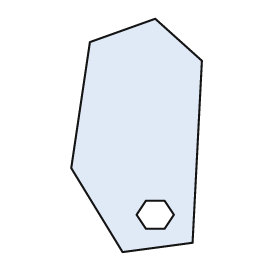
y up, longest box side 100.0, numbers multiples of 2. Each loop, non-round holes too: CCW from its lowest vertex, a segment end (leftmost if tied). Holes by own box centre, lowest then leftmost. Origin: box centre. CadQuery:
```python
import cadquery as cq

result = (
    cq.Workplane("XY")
    .moveTo(-6.0, -50.0)
    .lineTo(24.0, -46.0)
    .lineTo(28.0, 32.0)
    .lineTo(8.0, 50.0)
    .lineTo(-20.0, 40.0)
    .lineTo(-28.0, -14.0)
    .close()
    .moveTo(4.0, -40.0)
    .lineTo(12.0, -40.0)
    .lineTo(16.0, -34.0)
    .lineTo(12.0, -28.0)
    .lineTo(4.0, -28.0)
    .lineTo(0.0, -34.0)
    .close()
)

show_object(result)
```